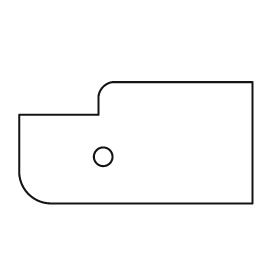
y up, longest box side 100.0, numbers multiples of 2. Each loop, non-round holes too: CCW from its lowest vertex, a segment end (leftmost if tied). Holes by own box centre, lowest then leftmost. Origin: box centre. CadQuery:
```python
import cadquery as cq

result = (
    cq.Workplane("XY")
    .moveTo(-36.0, -26.0)
    .lineTo(50.0, -26.0)
    .lineTo(50.0, 26.0)
    .lineTo(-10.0, 26.0)
    .threePointArc((-14.0, 24.0), (-16.0, 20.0))
    .lineTo(-16.0, 12.0)
    .lineTo(-50.0, 12.0)
    .lineTo(-50.0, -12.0)
    .threePointArc((-46.0, -22.0), (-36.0, -26.0))
    .close()
    .moveTo(-14.0, -6.0)
    .circle(4.0)
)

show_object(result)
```